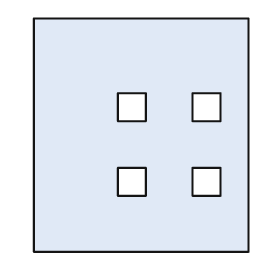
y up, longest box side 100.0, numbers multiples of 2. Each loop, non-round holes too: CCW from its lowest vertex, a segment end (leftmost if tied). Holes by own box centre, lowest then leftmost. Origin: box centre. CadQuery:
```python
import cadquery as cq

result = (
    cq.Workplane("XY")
    .moveTo(-46.0, -50.0)
    .lineTo(46.0, -50.0)
    .lineTo(46.0, 50.0)
    .lineTo(-46.0, 50.0)
    .close()
    .moveTo(-10.0, -26.0)
    .lineTo(2.0, -26.0)
    .lineTo(2.0, -14.0)
    .lineTo(-10.0, -14.0)
    .close()
    .moveTo(22.0, -26.0)
    .lineTo(34.0, -26.0)
    .lineTo(34.0, -14.0)
    .lineTo(22.0, -14.0)
    .close()
    .moveTo(-10.0, 6.0)
    .lineTo(2.0, 6.0)
    .lineTo(2.0, 18.0)
    .lineTo(-10.0, 18.0)
    .close()
    .moveTo(22.0, 6.0)
    .lineTo(34.0, 6.0)
    .lineTo(34.0, 18.0)
    .lineTo(22.0, 18.0)
    .close()
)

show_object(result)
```